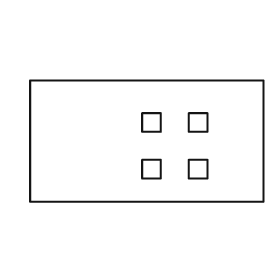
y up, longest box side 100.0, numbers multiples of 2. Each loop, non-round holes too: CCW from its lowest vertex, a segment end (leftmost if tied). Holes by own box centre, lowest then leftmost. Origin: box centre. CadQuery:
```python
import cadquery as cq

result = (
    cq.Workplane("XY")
    .moveTo(-50.0, -26.0)
    .lineTo(50.0, -26.0)
    .lineTo(50.0, 26.0)
    .lineTo(-50.0, 26.0)
    .close()
    .moveTo(-2.0, -16.0)
    .lineTo(6.0, -16.0)
    .lineTo(6.0, -8.0)
    .lineTo(-2.0, -8.0)
    .close()
    .moveTo(18.0, -16.0)
    .lineTo(26.0, -16.0)
    .lineTo(26.0, -8.0)
    .lineTo(18.0, -8.0)
    .close()
    .moveTo(-2.0, 4.0)
    .lineTo(6.0, 4.0)
    .lineTo(6.0, 12.0)
    .lineTo(-2.0, 12.0)
    .close()
    .moveTo(18.0, 4.0)
    .lineTo(26.0, 4.0)
    .lineTo(26.0, 12.0)
    .lineTo(18.0, 12.0)
    .close()
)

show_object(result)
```